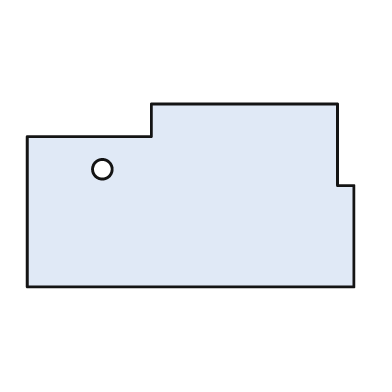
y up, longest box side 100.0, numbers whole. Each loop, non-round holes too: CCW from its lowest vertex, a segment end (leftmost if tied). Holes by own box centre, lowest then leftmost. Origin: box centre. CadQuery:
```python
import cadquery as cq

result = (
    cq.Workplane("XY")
    .moveTo(-50.0, -28.0)
    .lineTo(50.0, -28.0)
    .lineTo(50.0, 3.0)
    .lineTo(45.0, 3.0)
    .lineTo(45.0, 28.0)
    .lineTo(-12.0, 28.0)
    .lineTo(-12.0, 18.0)
    .lineTo(-50.0, 18.0)
    .close()
    .moveTo(-27.0, 8.0)
    .circle(3.0)
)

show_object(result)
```